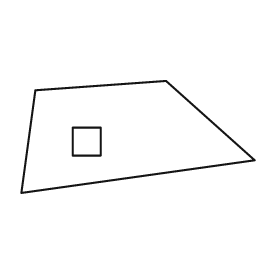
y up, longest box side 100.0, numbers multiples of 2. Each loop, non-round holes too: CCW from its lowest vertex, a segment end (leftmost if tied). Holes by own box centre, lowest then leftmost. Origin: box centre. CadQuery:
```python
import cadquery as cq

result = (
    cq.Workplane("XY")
    .moveTo(-50.0, -24.0)
    .lineTo(50.0, -10.0)
    .lineTo(12.0, 24.0)
    .lineTo(-44.0, 20.0)
    .close()
    .moveTo(-28.0, -8.0)
    .lineTo(-16.0, -8.0)
    .lineTo(-16.0, 4.0)
    .lineTo(-28.0, 4.0)
    .close()
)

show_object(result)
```